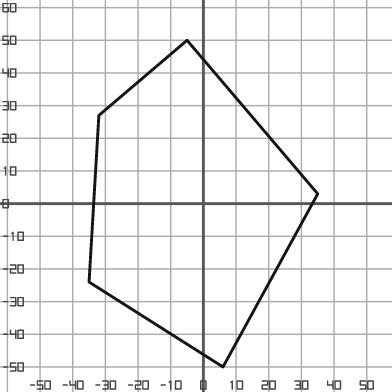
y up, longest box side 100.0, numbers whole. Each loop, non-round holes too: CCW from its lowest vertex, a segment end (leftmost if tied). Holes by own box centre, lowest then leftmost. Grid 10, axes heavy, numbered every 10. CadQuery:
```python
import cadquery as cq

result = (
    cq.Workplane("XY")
    .moveTo(6.0, -50.0)
    .lineTo(35.0, 3.0)
    .lineTo(-5.0, 50.0)
    .lineTo(-32.0, 27.0)
    .lineTo(-35.0, -24.0)
    .close()
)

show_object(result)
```